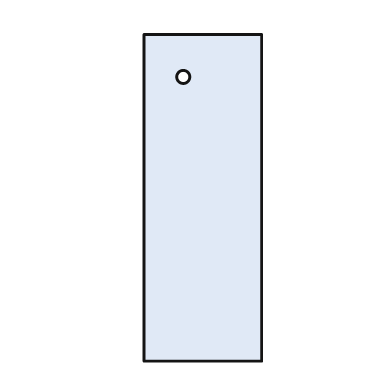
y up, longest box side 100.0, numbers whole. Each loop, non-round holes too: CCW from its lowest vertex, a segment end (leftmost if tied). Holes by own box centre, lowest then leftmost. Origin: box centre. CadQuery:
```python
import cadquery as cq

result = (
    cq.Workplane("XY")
    .moveTo(-18.0, -50.0)
    .lineTo(18.0, -50.0)
    .lineTo(18.0, 50.0)
    .lineTo(-18.0, 50.0)
    .close()
    .moveTo(-6.0, 37.0)
    .circle(2.0)
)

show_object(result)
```